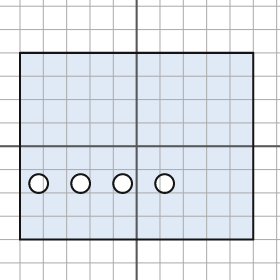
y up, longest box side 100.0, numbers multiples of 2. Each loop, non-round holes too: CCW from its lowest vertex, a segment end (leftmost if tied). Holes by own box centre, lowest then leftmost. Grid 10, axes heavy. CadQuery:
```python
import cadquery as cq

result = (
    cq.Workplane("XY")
    .moveTo(-50.0, -40.0)
    .lineTo(50.0, -40.0)
    .lineTo(50.0, 40.0)
    .lineTo(-50.0, 40.0)
    .close()
    .moveTo(-42.0, -16.0)
    .circle(4.0)
    .moveTo(-24.0, -16.0)
    .circle(4.0)
    .moveTo(-6.0, -16.0)
    .circle(4.0)
    .moveTo(12.0, -16.0)
    .circle(4.0)
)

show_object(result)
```